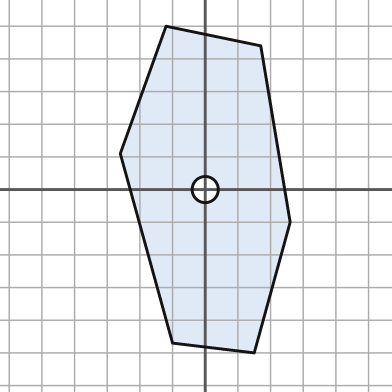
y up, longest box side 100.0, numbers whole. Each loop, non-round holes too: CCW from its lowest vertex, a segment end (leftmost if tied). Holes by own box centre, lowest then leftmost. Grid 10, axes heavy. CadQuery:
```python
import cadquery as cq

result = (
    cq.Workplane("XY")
    .moveTo(15.0, -50.0)
    .lineTo(26.0, -10.0)
    .lineTo(17.0, 44.0)
    .lineTo(-12.0, 50.0)
    .lineTo(-26.0, 11.0)
    .lineTo(-10.0, -47.0)
    .close()
    .moveTo(0.0, 0.0)
    .circle(4.0)
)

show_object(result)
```